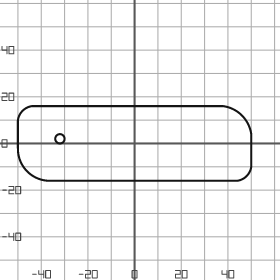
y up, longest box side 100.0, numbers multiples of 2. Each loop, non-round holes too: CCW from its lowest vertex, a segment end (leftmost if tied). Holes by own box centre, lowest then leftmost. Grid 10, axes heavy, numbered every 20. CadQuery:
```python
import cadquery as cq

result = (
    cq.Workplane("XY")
    .moveTo(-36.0, -16.0)
    .lineTo(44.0, -16.0)
    .threePointArc((48.0, -14.0), (50.0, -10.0))
    .lineTo(50.0, 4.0)
    .threePointArc((46.0, 12.0), (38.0, 16.0))
    .lineTo(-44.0, 16.0)
    .threePointArc((-48.0, 14.0), (-50.0, 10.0))
    .lineTo(-50.0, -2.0)
    .threePointArc((-46.0, -12.0), (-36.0, -16.0))
    .close()
    .moveTo(-32.0, 2.0)
    .circle(2.0)
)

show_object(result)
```